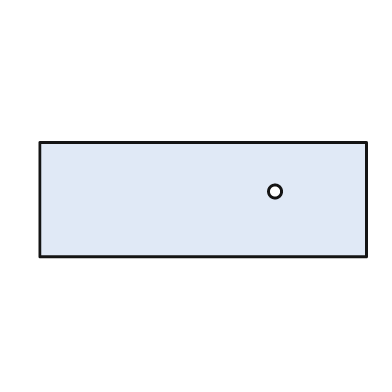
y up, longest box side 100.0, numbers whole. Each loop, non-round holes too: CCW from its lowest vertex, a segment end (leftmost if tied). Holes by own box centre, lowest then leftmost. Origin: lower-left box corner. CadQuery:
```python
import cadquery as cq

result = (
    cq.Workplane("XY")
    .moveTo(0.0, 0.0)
    .lineTo(100.0, 0.0)
    .lineTo(100.0, 35.0)
    .lineTo(0.0, 35.0)
    .close()
    .moveTo(72.0, 20.0)
    .circle(2.0)
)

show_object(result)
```